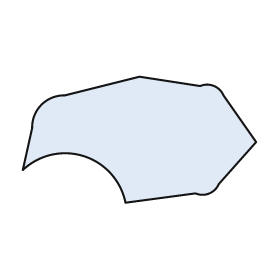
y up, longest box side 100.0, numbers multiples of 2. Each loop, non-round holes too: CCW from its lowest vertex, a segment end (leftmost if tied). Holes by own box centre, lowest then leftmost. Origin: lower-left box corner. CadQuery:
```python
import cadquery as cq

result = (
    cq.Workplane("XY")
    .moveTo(44.0, 0.0)
    .lineTo(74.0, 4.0)
    .threePointArc((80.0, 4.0), (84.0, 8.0))
    .lineTo(100.0, 26.0)
    .lineTo(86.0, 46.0)
    .threePointArc((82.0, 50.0), (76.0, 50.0))
    .lineTo(50.0, 54.0)
    .lineTo(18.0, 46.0)
    .threePointArc((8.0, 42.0), (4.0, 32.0))
    .lineTo(0.0, 14.0)
    .threePointArc((26.0, 20.0), (44.0, 0.0))
    .close()
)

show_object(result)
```